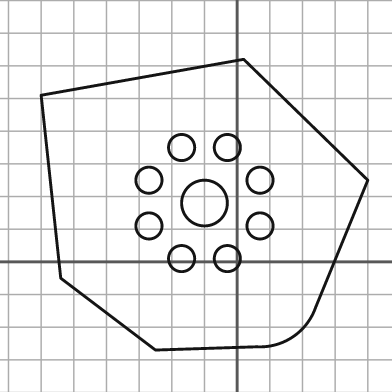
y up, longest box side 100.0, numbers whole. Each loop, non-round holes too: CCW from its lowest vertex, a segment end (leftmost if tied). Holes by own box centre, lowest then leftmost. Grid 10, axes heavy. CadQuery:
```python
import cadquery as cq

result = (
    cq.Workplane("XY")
    .moveTo(-25.0, -27.0)
    .lineTo(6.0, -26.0)
    .threePointArc((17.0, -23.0), (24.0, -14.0))
    .lineTo(40.0, 25.0)
    .lineTo(2.0, 62.0)
    .lineTo(-60.0, 51.0)
    .lineTo(-54.0, -5.0)
    .close()
    .moveTo(-17.0, 1.0)
    .circle(4.0)
    .moveTo(-3.0, 1.0)
    .circle(4.0)
    .moveTo(-27.0, 11.0)
    .circle(4.0)
    .moveTo(7.0, 11.0)
    .circle(4.0)
    .moveTo(-10.0, 18.0)
    .circle(7.0)
    .moveTo(-27.0, 25.0)
    .circle(4.0)
    .moveTo(7.0, 25.0)
    .circle(4.0)
    .moveTo(-17.0, 35.0)
    .circle(4.0)
    .moveTo(-3.0, 35.0)
    .circle(4.0)
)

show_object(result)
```